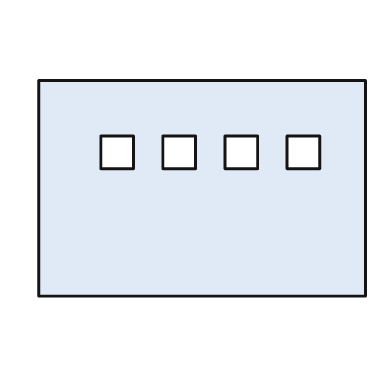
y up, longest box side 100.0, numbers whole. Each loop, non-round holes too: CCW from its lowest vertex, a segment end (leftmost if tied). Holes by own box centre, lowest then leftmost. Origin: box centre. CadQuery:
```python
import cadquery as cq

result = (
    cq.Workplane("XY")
    .moveTo(-50.0, -33.0)
    .lineTo(50.0, -33.0)
    .lineTo(50.0, 33.0)
    .lineTo(-50.0, 33.0)
    .close()
    .moveTo(-31.0, 6.0)
    .lineTo(-21.0, 6.0)
    .lineTo(-21.0, 16.0)
    .lineTo(-31.0, 16.0)
    .close()
    .moveTo(-12.0, 6.0)
    .lineTo(-2.0, 6.0)
    .lineTo(-2.0, 16.0)
    .lineTo(-12.0, 16.0)
    .close()
    .moveTo(7.0, 6.0)
    .lineTo(17.0, 6.0)
    .lineTo(17.0, 16.0)
    .lineTo(7.0, 16.0)
    .close()
    .moveTo(26.0, 6.0)
    .lineTo(36.0, 6.0)
    .lineTo(36.0, 16.0)
    .lineTo(26.0, 16.0)
    .close()
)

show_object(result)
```